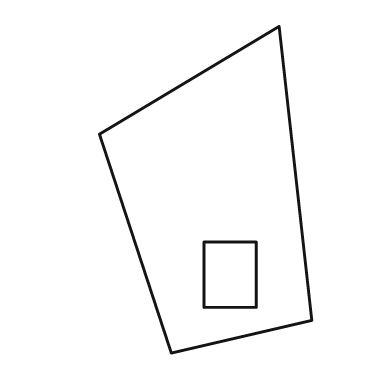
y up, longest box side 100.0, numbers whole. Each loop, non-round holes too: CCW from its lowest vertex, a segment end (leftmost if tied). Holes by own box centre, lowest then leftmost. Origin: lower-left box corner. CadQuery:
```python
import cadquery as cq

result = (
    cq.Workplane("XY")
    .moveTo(22.0, 0.0)
    .lineTo(65.0, 10.0)
    .lineTo(55.0, 100.0)
    .lineTo(0.0, 67.0)
    .close()
    .moveTo(32.0, 14.0)
    .lineTo(48.0, 14.0)
    .lineTo(48.0, 34.0)
    .lineTo(32.0, 34.0)
    .close()
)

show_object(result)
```